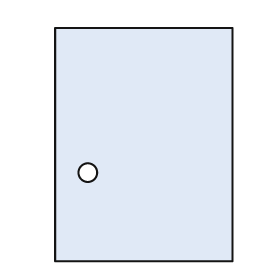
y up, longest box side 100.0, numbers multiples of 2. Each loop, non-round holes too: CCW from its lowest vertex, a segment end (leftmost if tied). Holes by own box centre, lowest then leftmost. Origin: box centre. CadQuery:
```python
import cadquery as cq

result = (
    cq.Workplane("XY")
    .moveTo(-38.0, -50.0)
    .lineTo(38.0, -50.0)
    .lineTo(38.0, 50.0)
    .lineTo(-38.0, 50.0)
    .close()
    .moveTo(-24.0, -12.0)
    .circle(4.0)
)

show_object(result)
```